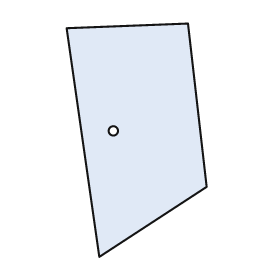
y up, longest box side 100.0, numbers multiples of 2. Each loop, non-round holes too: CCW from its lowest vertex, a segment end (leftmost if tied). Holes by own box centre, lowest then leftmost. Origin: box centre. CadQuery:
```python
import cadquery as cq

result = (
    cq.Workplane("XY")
    .moveTo(-16.0, -50.0)
    .lineTo(30.0, -20.0)
    .lineTo(22.0, 50.0)
    .lineTo(-30.0, 48.0)
    .close()
    .moveTo(-10.0, 4.0)
    .circle(2.0)
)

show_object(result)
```